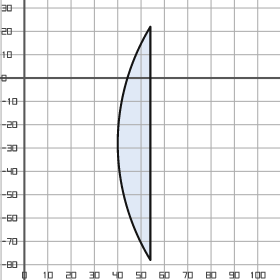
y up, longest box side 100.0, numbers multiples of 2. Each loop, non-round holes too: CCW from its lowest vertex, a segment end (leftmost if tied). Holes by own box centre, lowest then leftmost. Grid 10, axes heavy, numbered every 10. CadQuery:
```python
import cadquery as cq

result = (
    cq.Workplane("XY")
    .moveTo(54.0, -78.0)
    .lineTo(54.0, 22.0)
    .threePointArc((40.0, -28.0), (54.0, -78.0))
    .close()
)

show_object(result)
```